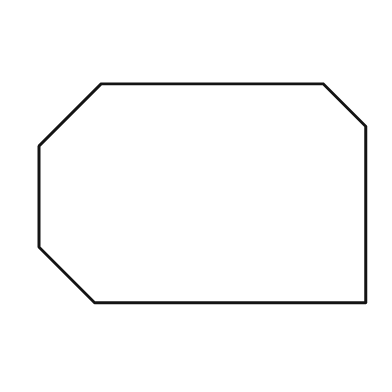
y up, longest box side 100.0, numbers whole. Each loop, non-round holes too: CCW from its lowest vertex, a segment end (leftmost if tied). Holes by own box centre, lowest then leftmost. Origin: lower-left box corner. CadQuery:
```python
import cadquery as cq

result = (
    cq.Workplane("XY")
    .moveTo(17.0, 0.0)
    .lineTo(100.0, 0.0)
    .lineTo(100.0, 54.0)
    .lineTo(87.0, 67.0)
    .lineTo(19.0, 67.0)
    .lineTo(0.0, 48.0)
    .lineTo(0.0, 17.0)
    .close()
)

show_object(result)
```